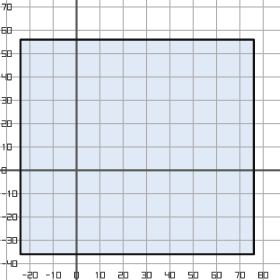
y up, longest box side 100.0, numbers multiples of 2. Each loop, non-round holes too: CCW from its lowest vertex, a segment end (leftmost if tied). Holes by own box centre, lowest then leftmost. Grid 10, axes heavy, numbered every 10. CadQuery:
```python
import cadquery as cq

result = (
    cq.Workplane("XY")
    .moveTo(-24.0, -36.0)
    .lineTo(76.0, -36.0)
    .lineTo(76.0, 56.0)
    .lineTo(-24.0, 56.0)
    .close()
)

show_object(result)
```